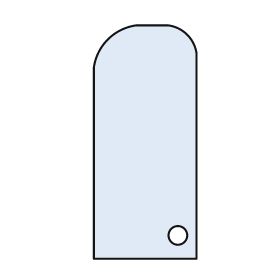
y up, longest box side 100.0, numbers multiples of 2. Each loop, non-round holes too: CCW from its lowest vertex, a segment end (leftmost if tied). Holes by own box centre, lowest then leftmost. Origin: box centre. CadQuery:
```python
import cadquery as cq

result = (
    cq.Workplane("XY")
    .moveTo(-22.0, -50.0)
    .lineTo(22.0, -50.0)
    .lineTo(22.0, 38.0)
    .threePointArc((18.0, 46.0), (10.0, 50.0))
    .lineTo(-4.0, 50.0)
    .threePointArc((-16.0, 44.0), (-22.0, 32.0))
    .close()
    .moveTo(14.0, -40.0)
    .circle(4.0)
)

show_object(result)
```